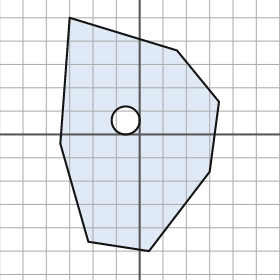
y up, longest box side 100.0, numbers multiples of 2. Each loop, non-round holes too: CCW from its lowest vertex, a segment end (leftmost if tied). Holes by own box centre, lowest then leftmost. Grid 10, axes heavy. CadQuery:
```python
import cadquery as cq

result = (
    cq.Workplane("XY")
    .moveTo(4.0, -50.0)
    .lineTo(30.0, -16.0)
    .lineTo(34.0, 14.0)
    .lineTo(16.0, 36.0)
    .lineTo(-30.0, 50.0)
    .lineTo(-34.0, -4.0)
    .lineTo(-22.0, -46.0)
    .close()
    .moveTo(-6.0, 6.0)
    .circle(6.0)
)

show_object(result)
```